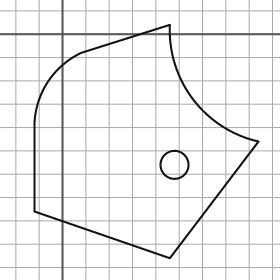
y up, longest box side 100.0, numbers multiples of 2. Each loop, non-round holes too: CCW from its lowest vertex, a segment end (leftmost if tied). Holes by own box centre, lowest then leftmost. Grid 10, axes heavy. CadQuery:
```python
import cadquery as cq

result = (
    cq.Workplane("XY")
    .moveTo(46.0, -96.0)
    .lineTo(84.0, -46.0)
    .threePointArc((56.0, -28.0), (46.0, 4.0))
    .lineTo(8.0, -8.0)
    .threePointArc((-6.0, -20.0), (-12.0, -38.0))
    .lineTo(-12.0, -76.0)
    .close()
    .moveTo(48.0, -56.0)
    .circle(6.0)
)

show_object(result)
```